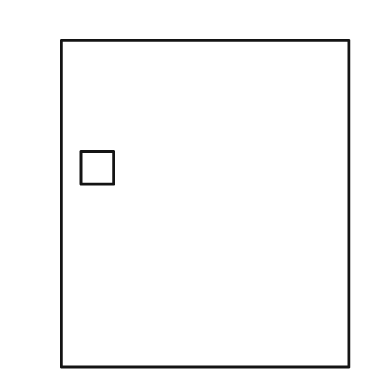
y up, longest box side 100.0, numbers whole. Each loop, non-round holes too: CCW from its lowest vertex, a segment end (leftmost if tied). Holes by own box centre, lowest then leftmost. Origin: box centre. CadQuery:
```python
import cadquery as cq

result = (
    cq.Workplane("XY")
    .moveTo(-44.0, -50.0)
    .lineTo(44.0, -50.0)
    .lineTo(44.0, 50.0)
    .lineTo(-44.0, 50.0)
    .close()
    .moveTo(-38.0, 6.0)
    .lineTo(-28.0, 6.0)
    .lineTo(-28.0, 16.0)
    .lineTo(-38.0, 16.0)
    .close()
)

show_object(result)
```